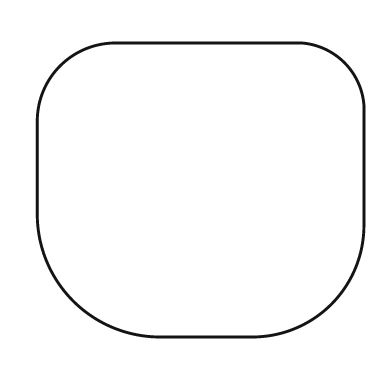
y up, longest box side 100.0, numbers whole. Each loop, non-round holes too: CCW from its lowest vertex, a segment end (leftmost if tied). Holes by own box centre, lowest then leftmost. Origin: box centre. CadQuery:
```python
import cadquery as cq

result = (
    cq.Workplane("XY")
    .moveTo(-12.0, -45.0)
    .lineTo(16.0, -45.0)
    .threePointArc((40.0, -35.0), (50.0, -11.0))
    .lineTo(50.0, 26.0)
    .threePointArc((44.0, 39.0), (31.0, 45.0))
    .lineTo(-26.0, 45.0)
    .threePointArc((-43.0, 38.0), (-50.0, 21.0))
    .lineTo(-50.0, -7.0)
    .threePointArc((-39.0, -34.0), (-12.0, -45.0))
    .close()
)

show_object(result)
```